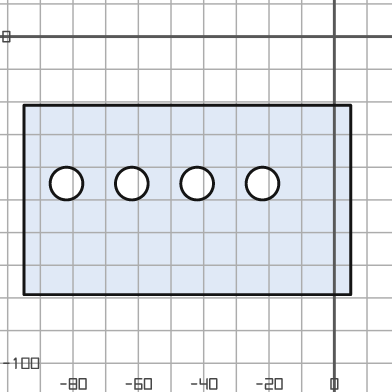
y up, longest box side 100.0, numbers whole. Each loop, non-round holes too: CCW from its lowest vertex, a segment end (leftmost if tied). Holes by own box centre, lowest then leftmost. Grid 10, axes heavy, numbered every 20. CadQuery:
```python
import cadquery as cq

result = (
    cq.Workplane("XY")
    .moveTo(-95.0, -79.0)
    .lineTo(5.0, -79.0)
    .lineTo(5.0, -21.0)
    .lineTo(-95.0, -21.0)
    .close()
    .moveTo(-82.0, -45.0)
    .circle(5.0)
    .moveTo(-62.0, -45.0)
    .circle(5.0)
    .moveTo(-42.0, -45.0)
    .circle(5.0)
    .moveTo(-22.0, -45.0)
    .circle(5.0)
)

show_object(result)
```